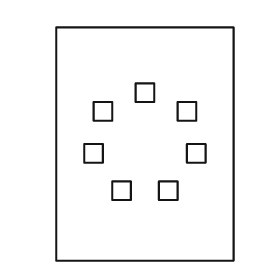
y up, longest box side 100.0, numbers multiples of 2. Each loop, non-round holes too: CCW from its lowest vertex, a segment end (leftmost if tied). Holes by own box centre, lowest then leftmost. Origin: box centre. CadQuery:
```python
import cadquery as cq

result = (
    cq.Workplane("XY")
    .moveTo(-38.0, -50.0)
    .lineTo(38.0, -50.0)
    .lineTo(38.0, 50.0)
    .lineTo(-38.0, 50.0)
    .close()
    .moveTo(-14.0, -24.0)
    .lineTo(-6.0, -24.0)
    .lineTo(-6.0, -16.0)
    .lineTo(-14.0, -16.0)
    .close()
    .moveTo(6.0, -24.0)
    .lineTo(14.0, -24.0)
    .lineTo(14.0, -16.0)
    .lineTo(6.0, -16.0)
    .close()
    .moveTo(-26.0, -8.0)
    .lineTo(-18.0, -8.0)
    .lineTo(-18.0, 0.0)
    .lineTo(-26.0, 0.0)
    .close()
    .moveTo(18.0, -8.0)
    .lineTo(26.0, -8.0)
    .lineTo(26.0, 0.0)
    .lineTo(18.0, 0.0)
    .close()
    .moveTo(-22.0, 10.0)
    .lineTo(-14.0, 10.0)
    .lineTo(-14.0, 18.0)
    .lineTo(-22.0, 18.0)
    .close()
    .moveTo(14.0, 10.0)
    .lineTo(22.0, 10.0)
    .lineTo(22.0, 18.0)
    .lineTo(14.0, 18.0)
    .close()
    .moveTo(-4.0, 18.0)
    .lineTo(4.0, 18.0)
    .lineTo(4.0, 26.0)
    .lineTo(-4.0, 26.0)
    .close()
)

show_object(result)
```